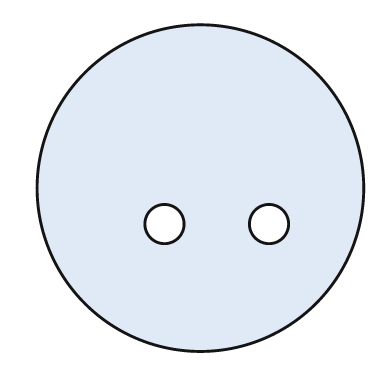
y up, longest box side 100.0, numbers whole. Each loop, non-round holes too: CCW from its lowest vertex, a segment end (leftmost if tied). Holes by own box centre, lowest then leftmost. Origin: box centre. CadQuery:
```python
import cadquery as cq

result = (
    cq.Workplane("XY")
    .moveTo(0.0, 0.0)
    .circle(50.0)
    .moveTo(-11.0, -11.0)
    .circle(6.0)
    .moveTo(21.0, -11.0)
    .circle(6.0)
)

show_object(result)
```